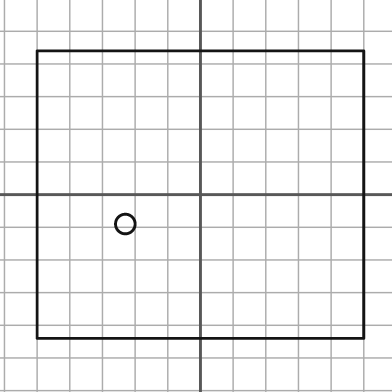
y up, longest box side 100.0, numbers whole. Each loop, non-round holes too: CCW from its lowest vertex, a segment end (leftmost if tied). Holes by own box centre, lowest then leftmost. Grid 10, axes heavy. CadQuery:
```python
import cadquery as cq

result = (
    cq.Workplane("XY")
    .moveTo(-50.0, -44.0)
    .lineTo(50.0, -44.0)
    .lineTo(50.0, 44.0)
    .lineTo(-50.0, 44.0)
    .close()
    .moveTo(-23.0, -9.0)
    .circle(3.0)
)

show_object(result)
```